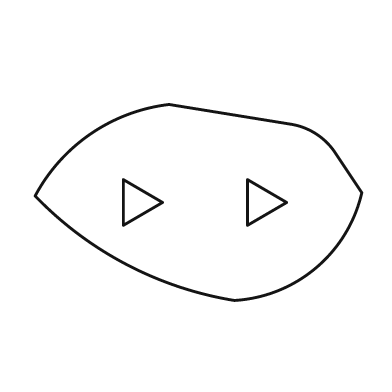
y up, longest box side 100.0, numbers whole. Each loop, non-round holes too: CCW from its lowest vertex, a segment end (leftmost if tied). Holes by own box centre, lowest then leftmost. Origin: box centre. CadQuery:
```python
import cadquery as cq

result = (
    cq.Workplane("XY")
    .moveTo(11.0, -30.0)
    .threePointArc((36.0, -20.0), (50.0, 3.0))
    .lineTo(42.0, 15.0)
    .threePointArc((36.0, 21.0), (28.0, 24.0))
    .lineTo(-9.0, 30.0)
    .threePointArc((-33.0, 21.0), (-50.0, 2.0))
    .threePointArc((-22.0, -19.0), (11.0, -30.0))
    .close()
    .moveTo(-23.0, -7.0)
    .lineTo(-11.0, 0.0)
    .lineTo(-23.0, 7.0)
    .close()
    .moveTo(15.0, -7.0)
    .lineTo(27.0, 0.0)
    .lineTo(15.0, 7.0)
    .close()
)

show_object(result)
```